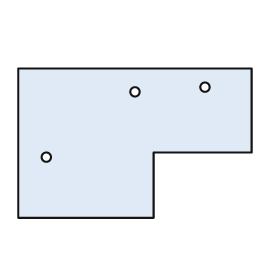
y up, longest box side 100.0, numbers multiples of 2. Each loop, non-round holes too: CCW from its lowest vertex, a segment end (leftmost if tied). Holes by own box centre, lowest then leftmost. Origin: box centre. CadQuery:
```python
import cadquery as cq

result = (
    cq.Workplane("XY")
    .moveTo(-50.0, -32.0)
    .lineTo(8.0, -32.0)
    .lineTo(8.0, -4.0)
    .lineTo(50.0, -4.0)
    .lineTo(50.0, 32.0)
    .lineTo(-50.0, 32.0)
    .close()
    .moveTo(-38.0, -6.0)
    .circle(2.0)
    .moveTo(0.0, 22.0)
    .circle(2.0)
    .moveTo(30.0, 24.0)
    .circle(2.0)
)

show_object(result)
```